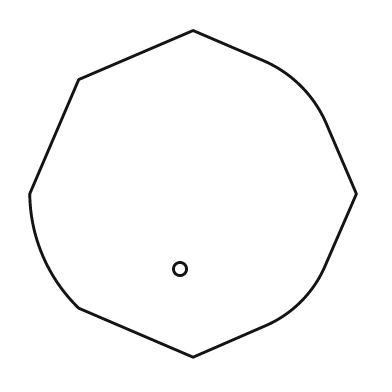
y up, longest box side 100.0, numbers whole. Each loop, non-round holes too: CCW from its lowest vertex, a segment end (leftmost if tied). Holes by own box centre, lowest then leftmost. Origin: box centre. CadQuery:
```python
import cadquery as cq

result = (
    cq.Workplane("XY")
    .moveTo(0.0, -50.0)
    .lineTo(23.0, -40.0)
    .threePointArc((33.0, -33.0), (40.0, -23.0))
    .lineTo(50.0, 0.0)
    .lineTo(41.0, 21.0)
    .threePointArc((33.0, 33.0), (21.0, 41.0))
    .lineTo(0.0, 50.0)
    .lineTo(-35.0, 35.0)
    .lineTo(-50.0, 0.0)
    .threePointArc((-46.0, -19.0), (-35.0, -35.0))
    .close()
    .moveTo(-4.0, -23.0)
    .circle(2.0)
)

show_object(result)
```